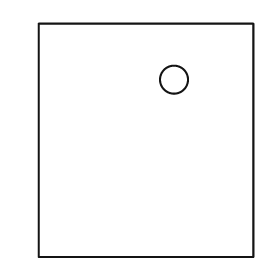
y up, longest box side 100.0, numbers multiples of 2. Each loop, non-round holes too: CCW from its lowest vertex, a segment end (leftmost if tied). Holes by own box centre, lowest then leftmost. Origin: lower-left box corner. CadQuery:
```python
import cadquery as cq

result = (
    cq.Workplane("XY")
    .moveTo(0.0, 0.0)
    .lineTo(92.0, 0.0)
    .lineTo(92.0, 100.0)
    .lineTo(0.0, 100.0)
    .close()
    .moveTo(58.0, 76.0)
    .circle(6.0)
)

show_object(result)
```